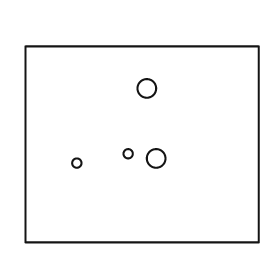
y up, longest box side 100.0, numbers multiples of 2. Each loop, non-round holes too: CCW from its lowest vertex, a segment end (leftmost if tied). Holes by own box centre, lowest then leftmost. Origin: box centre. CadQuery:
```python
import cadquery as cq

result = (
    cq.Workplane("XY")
    .moveTo(-50.0, -42.0)
    .lineTo(50.0, -42.0)
    .lineTo(50.0, 42.0)
    .lineTo(-50.0, 42.0)
    .close()
    .moveTo(-28.0, -8.0)
    .circle(2.0)
    .moveTo(6.0, -6.0)
    .circle(4.0)
    .moveTo(-6.0, -4.0)
    .circle(2.0)
    .moveTo(2.0, 24.0)
    .circle(4.0)
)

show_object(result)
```